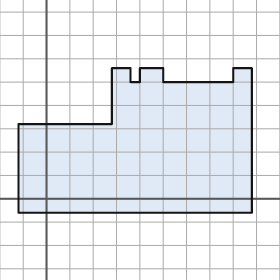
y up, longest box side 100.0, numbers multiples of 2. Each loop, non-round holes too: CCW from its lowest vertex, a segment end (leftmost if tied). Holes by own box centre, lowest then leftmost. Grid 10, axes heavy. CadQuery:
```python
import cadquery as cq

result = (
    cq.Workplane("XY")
    .moveTo(-12.0, -6.0)
    .lineTo(88.0, -6.0)
    .lineTo(88.0, 56.0)
    .lineTo(80.0, 56.0)
    .lineTo(80.0, 50.0)
    .lineTo(50.0, 50.0)
    .lineTo(50.0, 56.0)
    .lineTo(40.0, 56.0)
    .lineTo(40.0, 50.0)
    .lineTo(36.0, 50.0)
    .lineTo(36.0, 56.0)
    .lineTo(28.0, 56.0)
    .lineTo(28.0, 32.0)
    .lineTo(-12.0, 32.0)
    .close()
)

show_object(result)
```